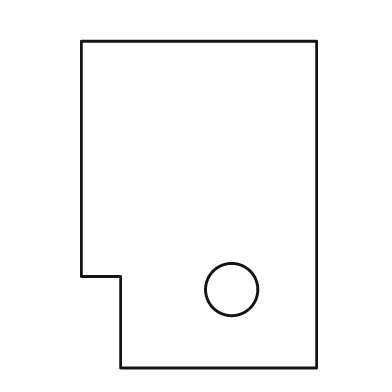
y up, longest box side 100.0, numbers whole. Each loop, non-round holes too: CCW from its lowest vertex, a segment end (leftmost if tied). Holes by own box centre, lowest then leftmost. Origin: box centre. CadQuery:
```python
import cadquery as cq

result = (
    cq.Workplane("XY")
    .moveTo(-24.0, -50.0)
    .lineTo(36.0, -50.0)
    .lineTo(36.0, 50.0)
    .lineTo(-36.0, 50.0)
    .lineTo(-36.0, -22.0)
    .lineTo(-24.0, -22.0)
    .close()
    .moveTo(10.0, -26.0)
    .circle(8.0)
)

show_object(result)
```